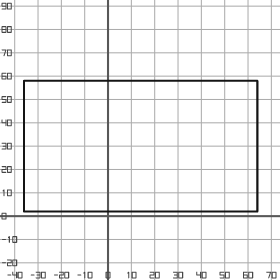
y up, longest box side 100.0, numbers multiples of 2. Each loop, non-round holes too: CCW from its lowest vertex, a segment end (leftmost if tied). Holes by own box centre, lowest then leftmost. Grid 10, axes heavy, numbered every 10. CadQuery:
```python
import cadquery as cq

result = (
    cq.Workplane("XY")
    .moveTo(-36.0, 2.0)
    .lineTo(64.0, 2.0)
    .lineTo(64.0, 58.0)
    .lineTo(-36.0, 58.0)
    .close()
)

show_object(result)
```